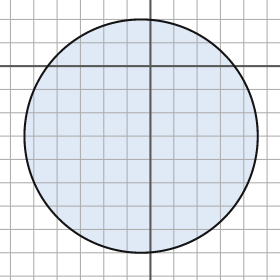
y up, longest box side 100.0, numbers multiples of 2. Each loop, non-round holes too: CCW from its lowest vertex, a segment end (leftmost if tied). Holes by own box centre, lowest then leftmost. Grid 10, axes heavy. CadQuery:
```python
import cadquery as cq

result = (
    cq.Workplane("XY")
    .moveTo(-4.0, -30.0)
    .circle(50.0)
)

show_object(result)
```